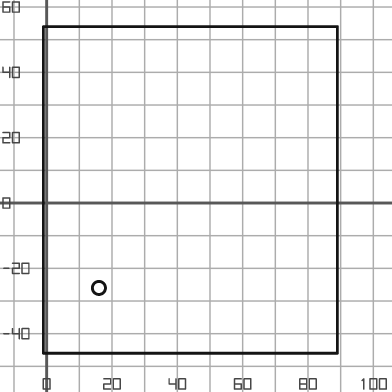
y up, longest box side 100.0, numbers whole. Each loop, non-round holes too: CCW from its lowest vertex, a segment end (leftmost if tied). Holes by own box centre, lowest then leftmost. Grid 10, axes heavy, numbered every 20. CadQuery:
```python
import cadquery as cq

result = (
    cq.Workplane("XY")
    .moveTo(-1.0, -46.0)
    .lineTo(89.0, -46.0)
    .lineTo(89.0, 54.0)
    .lineTo(-1.0, 54.0)
    .close()
    .moveTo(16.0, -26.0)
    .circle(2.0)
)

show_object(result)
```